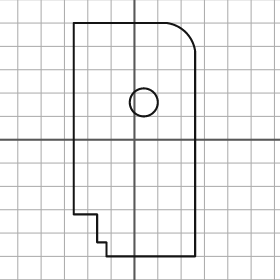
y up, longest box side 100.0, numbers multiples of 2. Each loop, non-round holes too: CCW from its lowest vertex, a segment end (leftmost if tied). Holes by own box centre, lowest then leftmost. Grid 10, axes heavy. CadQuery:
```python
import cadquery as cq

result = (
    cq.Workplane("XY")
    .moveTo(-12.0, -50.0)
    .lineTo(26.0, -50.0)
    .lineTo(26.0, 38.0)
    .threePointArc((22.0, 46.0), (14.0, 50.0))
    .lineTo(-26.0, 50.0)
    .lineTo(-26.0, -32.0)
    .lineTo(-16.0, -32.0)
    .lineTo(-16.0, -44.0)
    .lineTo(-12.0, -44.0)
    .close()
    .moveTo(4.0, 16.0)
    .circle(6.0)
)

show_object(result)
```